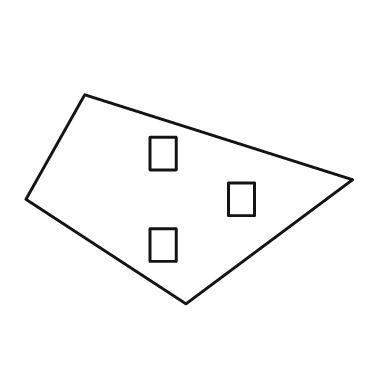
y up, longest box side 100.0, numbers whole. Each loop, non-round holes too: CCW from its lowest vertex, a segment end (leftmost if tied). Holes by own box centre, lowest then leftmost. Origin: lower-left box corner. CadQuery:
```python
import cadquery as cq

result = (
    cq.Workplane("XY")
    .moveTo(49.0, 0.0)
    .lineTo(100.0, 38.0)
    .lineTo(18.0, 64.0)
    .lineTo(0.0, 32.0)
    .close()
    .moveTo(38.0, 13.0)
    .lineTo(46.0, 13.0)
    .lineTo(46.0, 23.0)
    .lineTo(38.0, 23.0)
    .close()
    .moveTo(62.0, 27.0)
    .lineTo(70.0, 27.0)
    .lineTo(70.0, 37.0)
    .lineTo(62.0, 37.0)
    .close()
    .moveTo(38.0, 41.0)
    .lineTo(46.0, 41.0)
    .lineTo(46.0, 51.0)
    .lineTo(38.0, 51.0)
    .close()
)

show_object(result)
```